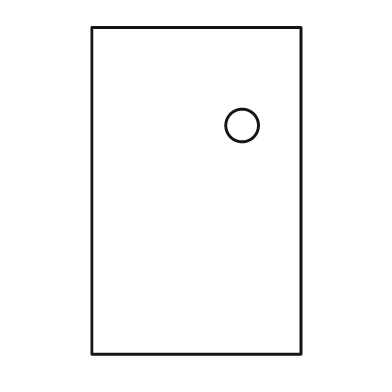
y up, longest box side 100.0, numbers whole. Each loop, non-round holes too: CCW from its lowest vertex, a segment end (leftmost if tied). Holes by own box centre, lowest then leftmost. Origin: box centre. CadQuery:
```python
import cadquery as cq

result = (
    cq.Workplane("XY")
    .moveTo(-32.0, -50.0)
    .lineTo(32.0, -50.0)
    .lineTo(32.0, 50.0)
    .lineTo(-32.0, 50.0)
    .close()
    .moveTo(14.0, 20.0)
    .circle(5.0)
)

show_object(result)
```